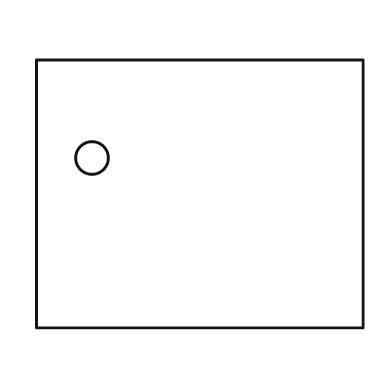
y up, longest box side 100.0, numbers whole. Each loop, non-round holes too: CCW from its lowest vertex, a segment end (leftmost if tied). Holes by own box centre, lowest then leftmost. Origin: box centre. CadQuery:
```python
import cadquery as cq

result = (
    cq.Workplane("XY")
    .moveTo(-50.0, -41.0)
    .lineTo(50.0, -41.0)
    .lineTo(50.0, 41.0)
    .lineTo(-50.0, 41.0)
    .close()
    .moveTo(-33.0, 11.0)
    .circle(5.0)
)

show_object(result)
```